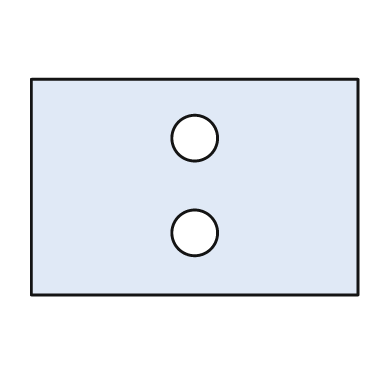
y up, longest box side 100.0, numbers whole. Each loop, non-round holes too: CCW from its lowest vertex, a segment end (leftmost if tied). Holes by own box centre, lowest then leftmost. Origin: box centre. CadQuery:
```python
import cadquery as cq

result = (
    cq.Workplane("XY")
    .moveTo(-50.0, -33.0)
    .lineTo(50.0, -33.0)
    .lineTo(50.0, 33.0)
    .lineTo(-50.0, 33.0)
    .close()
    .moveTo(0.0, -14.0)
    .circle(7.0)
    .moveTo(0.0, 15.0)
    .circle(7.0)
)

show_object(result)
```